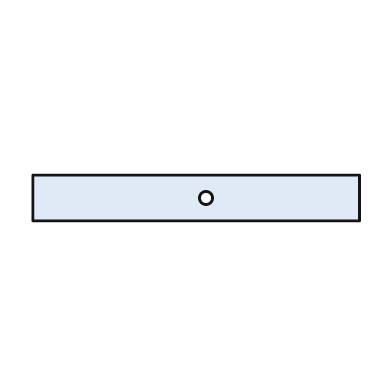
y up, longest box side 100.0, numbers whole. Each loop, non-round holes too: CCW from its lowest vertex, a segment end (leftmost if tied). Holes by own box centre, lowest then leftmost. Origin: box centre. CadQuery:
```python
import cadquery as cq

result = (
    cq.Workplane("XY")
    .moveTo(-50.0, -7.0)
    .lineTo(50.0, -7.0)
    .lineTo(50.0, 7.0)
    .lineTo(-50.0, 7.0)
    .close()
    .moveTo(3.0, 0.0)
    .circle(2.0)
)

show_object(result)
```